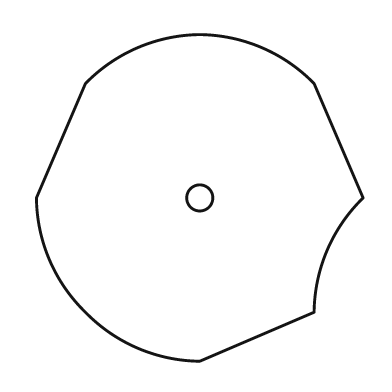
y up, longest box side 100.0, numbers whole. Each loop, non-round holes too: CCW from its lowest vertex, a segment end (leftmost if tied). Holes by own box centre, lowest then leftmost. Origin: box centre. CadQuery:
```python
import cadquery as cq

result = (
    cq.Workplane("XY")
    .moveTo(0.0, -50.0)
    .lineTo(35.0, -35.0)
    .threePointArc((39.0, -16.0), (50.0, 0.0))
    .lineTo(35.0, 35.0)
    .threePointArc((19.0, 46.0), (0.0, 50.0))
    .threePointArc((-19.0, 46.0), (-35.0, 35.0))
    .lineTo(-50.0, 0.0)
    .threePointArc((-46.0, -19.0), (-35.0, -35.0))
    .threePointArc((-19.0, -46.0), (0.0, -50.0))
    .close()
    .moveTo(0.0, 0.0)
    .circle(4.0)
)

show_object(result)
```